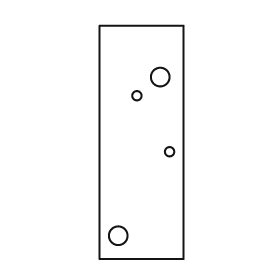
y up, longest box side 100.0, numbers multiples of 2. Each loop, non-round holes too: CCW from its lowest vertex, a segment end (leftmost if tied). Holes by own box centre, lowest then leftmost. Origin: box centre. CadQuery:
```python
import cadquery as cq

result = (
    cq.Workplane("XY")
    .moveTo(-18.0, -50.0)
    .lineTo(18.0, -50.0)
    .lineTo(18.0, 50.0)
    .lineTo(-18.0, 50.0)
    .close()
    .moveTo(-10.0, -40.0)
    .circle(4.0)
    .moveTo(12.0, -4.0)
    .circle(2.0)
    .moveTo(-2.0, 20.0)
    .circle(2.0)
    .moveTo(8.0, 28.0)
    .circle(4.0)
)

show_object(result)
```